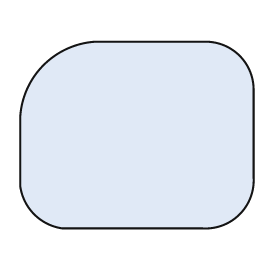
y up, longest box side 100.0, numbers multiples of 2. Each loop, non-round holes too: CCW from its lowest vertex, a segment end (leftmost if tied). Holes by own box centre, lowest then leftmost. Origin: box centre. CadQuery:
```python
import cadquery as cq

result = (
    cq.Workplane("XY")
    .moveTo(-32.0, -40.0)
    .lineTo(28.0, -40.0)
    .threePointArc((44.0, -34.0), (50.0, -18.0))
    .lineTo(50.0, 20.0)
    .threePointArc((44.0, 34.0), (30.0, 40.0))
    .lineTo(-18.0, 40.0)
    .threePointArc((-40.0, 30.0), (-50.0, 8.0))
    .lineTo(-50.0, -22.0)
    .threePointArc((-44.0, -34.0), (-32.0, -40.0))
    .close()
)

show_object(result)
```